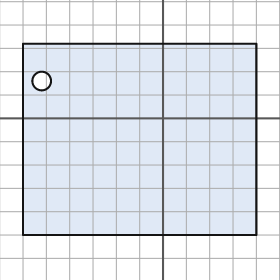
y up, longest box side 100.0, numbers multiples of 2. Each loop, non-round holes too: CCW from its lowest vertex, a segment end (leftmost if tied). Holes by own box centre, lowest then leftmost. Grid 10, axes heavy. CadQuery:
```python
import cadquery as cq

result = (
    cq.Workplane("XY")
    .moveTo(-60.0, -50.0)
    .lineTo(40.0, -50.0)
    .lineTo(40.0, 32.0)
    .lineTo(-60.0, 32.0)
    .close()
    .moveTo(-52.0, 16.0)
    .circle(4.0)
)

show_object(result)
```